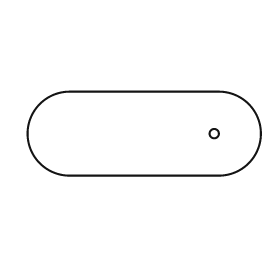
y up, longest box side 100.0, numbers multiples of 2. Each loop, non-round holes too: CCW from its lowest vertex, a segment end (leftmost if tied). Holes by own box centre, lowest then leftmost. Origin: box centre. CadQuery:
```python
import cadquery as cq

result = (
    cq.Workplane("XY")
    .moveTo(-32.0, -18.0)
    .lineTo(32.0, -18.0)
    .threePointArc((50.0, 0.0), (32.0, 18.0))
    .lineTo(-32.0, 18.0)
    .threePointArc((-50.0, 0.0), (-32.0, -18.0))
    .close()
    .moveTo(30.0, 0.0)
    .circle(2.0)
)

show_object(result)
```